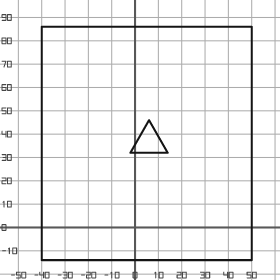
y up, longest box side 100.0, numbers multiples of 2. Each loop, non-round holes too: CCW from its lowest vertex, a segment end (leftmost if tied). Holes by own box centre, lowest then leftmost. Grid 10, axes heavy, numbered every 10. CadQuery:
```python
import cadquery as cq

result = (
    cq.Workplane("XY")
    .moveTo(-40.0, -14.0)
    .lineTo(50.0, -14.0)
    .lineTo(50.0, 86.0)
    .lineTo(-40.0, 86.0)
    .close()
    .moveTo(-2.0, 32.0)
    .lineTo(14.0, 32.0)
    .lineTo(6.0, 46.0)
    .close()
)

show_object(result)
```